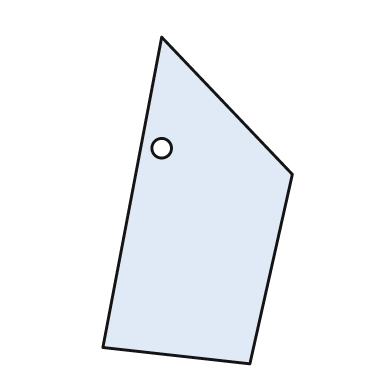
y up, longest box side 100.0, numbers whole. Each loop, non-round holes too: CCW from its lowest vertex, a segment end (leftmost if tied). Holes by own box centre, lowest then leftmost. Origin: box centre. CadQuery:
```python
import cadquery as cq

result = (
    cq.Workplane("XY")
    .moveTo(16.0, -50.0)
    .lineTo(29.0, 8.0)
    .lineTo(-11.0, 50.0)
    .lineTo(-29.0, -45.0)
    .close()
    .moveTo(-11.0, 16.0)
    .circle(3.0)
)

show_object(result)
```